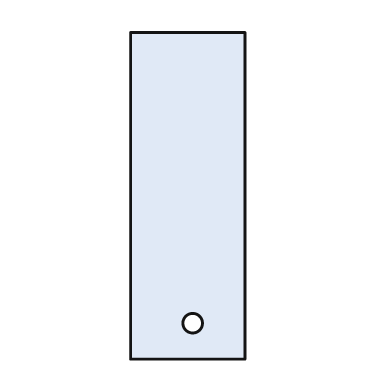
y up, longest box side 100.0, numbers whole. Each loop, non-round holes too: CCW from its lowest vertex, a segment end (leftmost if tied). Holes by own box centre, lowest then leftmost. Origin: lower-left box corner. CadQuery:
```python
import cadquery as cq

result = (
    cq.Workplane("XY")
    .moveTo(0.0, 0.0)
    .lineTo(35.0, 0.0)
    .lineTo(35.0, 100.0)
    .lineTo(0.0, 100.0)
    .close()
    .moveTo(19.0, 11.0)
    .circle(3.0)
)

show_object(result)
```